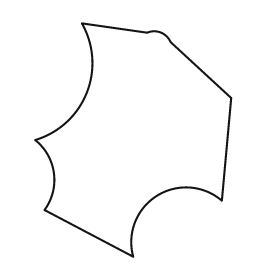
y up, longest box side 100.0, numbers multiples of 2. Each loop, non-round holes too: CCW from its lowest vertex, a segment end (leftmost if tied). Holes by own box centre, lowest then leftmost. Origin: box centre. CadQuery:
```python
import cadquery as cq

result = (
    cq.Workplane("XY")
    .moveTo(0.0, -50.0)
    .threePointArc((10.0, -24.0), (38.0, -26.0))
    .lineTo(42.0, 18.0)
    .lineTo(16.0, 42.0)
    .threePointArc((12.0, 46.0), (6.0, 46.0))
    .lineTo(-22.0, 50.0)
    .threePointArc((-20.0, 20.0), (-42.0, 0.0))
    .threePointArc((-34.0, -14.0), (-38.0, -30.0))
    .close()
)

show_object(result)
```